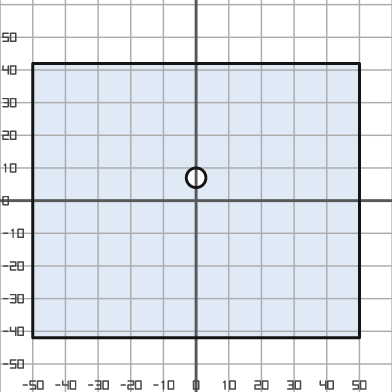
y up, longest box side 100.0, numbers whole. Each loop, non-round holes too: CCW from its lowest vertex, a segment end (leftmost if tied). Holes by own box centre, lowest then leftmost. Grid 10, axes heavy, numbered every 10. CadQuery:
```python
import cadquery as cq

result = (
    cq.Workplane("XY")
    .moveTo(-50.0, -42.0)
    .lineTo(50.0, -42.0)
    .lineTo(50.0, 42.0)
    .lineTo(-50.0, 42.0)
    .close()
    .moveTo(0.0, 7.0)
    .circle(3.0)
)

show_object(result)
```